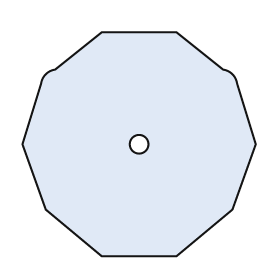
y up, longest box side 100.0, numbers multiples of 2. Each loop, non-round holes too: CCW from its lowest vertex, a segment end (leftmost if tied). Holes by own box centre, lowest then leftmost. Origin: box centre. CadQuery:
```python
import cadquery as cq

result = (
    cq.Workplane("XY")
    .moveTo(-16.0, -48.0)
    .lineTo(16.0, -48.0)
    .lineTo(40.0, -28.0)
    .lineTo(50.0, 0.0)
    .lineTo(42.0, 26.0)
    .threePointArc((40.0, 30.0), (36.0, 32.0))
    .lineTo(16.0, 48.0)
    .lineTo(-16.0, 48.0)
    .lineTo(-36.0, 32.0)
    .threePointArc((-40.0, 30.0), (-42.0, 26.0))
    .lineTo(-50.0, 0.0)
    .lineTo(-40.0, -28.0)
    .close()
    .moveTo(0.0, 0.0)
    .circle(4.0)
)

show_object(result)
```